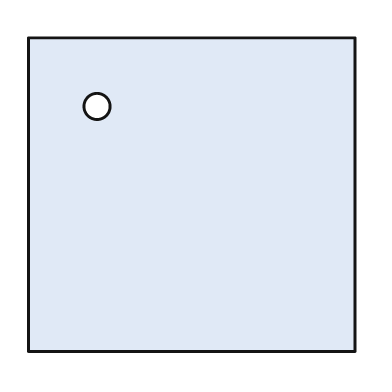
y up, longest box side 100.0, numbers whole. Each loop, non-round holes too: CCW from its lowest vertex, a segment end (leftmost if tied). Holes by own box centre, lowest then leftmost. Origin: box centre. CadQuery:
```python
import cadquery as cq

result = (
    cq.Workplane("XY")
    .moveTo(-50.0, -48.0)
    .lineTo(50.0, -48.0)
    .lineTo(50.0, 48.0)
    .lineTo(-50.0, 48.0)
    .close()
    .moveTo(-29.0, 27.0)
    .circle(4.0)
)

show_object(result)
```